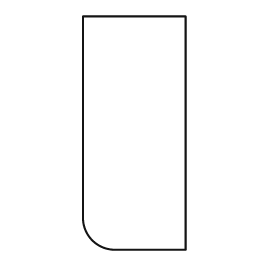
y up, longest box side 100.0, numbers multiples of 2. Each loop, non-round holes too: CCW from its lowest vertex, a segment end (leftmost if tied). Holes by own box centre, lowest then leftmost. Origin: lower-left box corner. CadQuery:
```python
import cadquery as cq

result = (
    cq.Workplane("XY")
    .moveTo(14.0, 0.0)
    .lineTo(44.0, 0.0)
    .lineTo(44.0, 100.0)
    .lineTo(0.0, 100.0)
    .lineTo(0.0, 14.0)
    .threePointArc((4.0, 4.0), (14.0, 0.0))
    .close()
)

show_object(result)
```